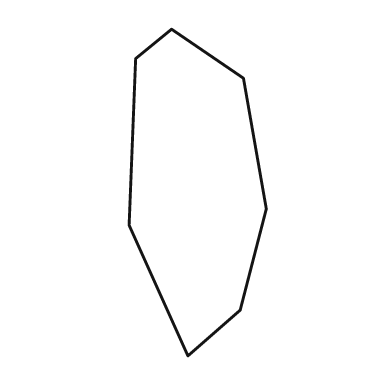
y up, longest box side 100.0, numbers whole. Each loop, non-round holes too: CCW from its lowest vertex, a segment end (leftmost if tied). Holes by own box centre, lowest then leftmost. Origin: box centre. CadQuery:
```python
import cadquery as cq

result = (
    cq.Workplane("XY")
    .moveTo(-3.0, -50.0)
    .lineTo(13.0, -36.0)
    .lineTo(21.0, -5.0)
    .lineTo(14.0, 35.0)
    .lineTo(-8.0, 50.0)
    .lineTo(-19.0, 41.0)
    .lineTo(-21.0, -10.0)
    .close()
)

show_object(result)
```